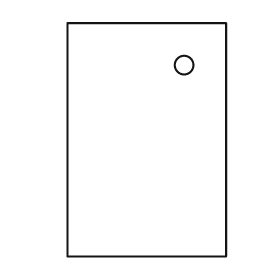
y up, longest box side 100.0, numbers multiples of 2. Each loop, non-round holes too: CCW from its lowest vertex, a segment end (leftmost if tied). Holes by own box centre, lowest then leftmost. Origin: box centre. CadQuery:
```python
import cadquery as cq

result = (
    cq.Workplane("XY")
    .moveTo(-34.0, -50.0)
    .lineTo(34.0, -50.0)
    .lineTo(34.0, 50.0)
    .lineTo(-34.0, 50.0)
    .close()
    .moveTo(16.0, 32.0)
    .circle(4.0)
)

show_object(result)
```